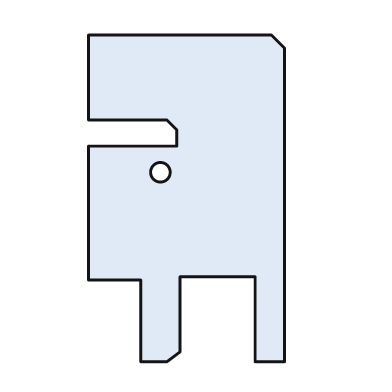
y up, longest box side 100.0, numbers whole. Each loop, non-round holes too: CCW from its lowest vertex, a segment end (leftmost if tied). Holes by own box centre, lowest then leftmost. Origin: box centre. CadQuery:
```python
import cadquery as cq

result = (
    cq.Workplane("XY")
    .moveTo(-14.0, -50.0)
    .lineTo(-6.0, -50.0)
    .lineTo(-2.0, -47.0)
    .lineTo(-2.0, -24.0)
    .lineTo(21.0, -24.0)
    .lineTo(21.0, -50.0)
    .lineTo(30.0, -50.0)
    .lineTo(30.0, 46.0)
    .lineTo(26.0, 50.0)
    .lineTo(-30.0, 50.0)
    .lineTo(-30.0, 24.0)
    .lineTo(-6.0, 24.0)
    .lineTo(-3.0, 21.0)
    .lineTo(-3.0, 16.0)
    .lineTo(-30.0, 16.0)
    .lineTo(-30.0, -25.0)
    .lineTo(-14.0, -25.0)
    .close()
    .moveTo(-8.0, 8.0)
    .circle(3.0)
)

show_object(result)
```